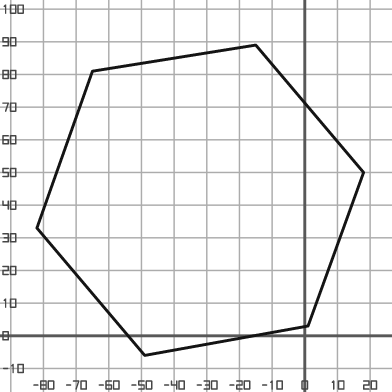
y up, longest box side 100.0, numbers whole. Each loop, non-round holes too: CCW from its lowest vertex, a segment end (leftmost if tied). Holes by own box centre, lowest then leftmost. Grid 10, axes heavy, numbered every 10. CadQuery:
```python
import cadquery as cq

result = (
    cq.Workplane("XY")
    .moveTo(-49.0, -6.0)
    .lineTo(1.0, 3.0)
    .lineTo(18.0, 50.0)
    .lineTo(-15.0, 89.0)
    .lineTo(-65.0, 81.0)
    .lineTo(-82.0, 33.0)
    .close()
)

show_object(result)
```